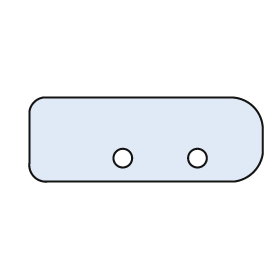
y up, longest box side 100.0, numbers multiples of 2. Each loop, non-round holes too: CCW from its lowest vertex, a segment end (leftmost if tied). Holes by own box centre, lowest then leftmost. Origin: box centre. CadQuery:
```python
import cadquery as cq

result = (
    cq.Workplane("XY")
    .moveTo(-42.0, -18.0)
    .lineTo(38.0, -18.0)
    .threePointArc((46.0, -14.0), (50.0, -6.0))
    .lineTo(50.0, 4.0)
    .threePointArc((46.0, 14.0), (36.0, 18.0))
    .lineTo(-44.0, 18.0)
    .threePointArc((-48.0, 16.0), (-50.0, 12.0))
    .lineTo(-50.0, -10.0)
    .threePointArc((-48.0, -16.0), (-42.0, -18.0))
    .close()
    .moveTo(-10.0, -8.0)
    .circle(4.0)
    .moveTo(22.0, -8.0)
    .circle(4.0)
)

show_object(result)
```